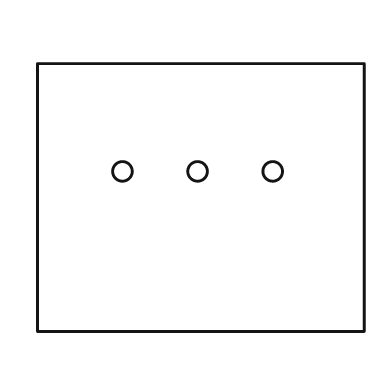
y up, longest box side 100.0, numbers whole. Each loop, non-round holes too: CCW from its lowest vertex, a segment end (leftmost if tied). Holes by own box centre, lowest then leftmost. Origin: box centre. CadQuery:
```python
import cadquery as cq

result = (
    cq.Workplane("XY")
    .moveTo(-50.0, -41.0)
    .lineTo(50.0, -41.0)
    .lineTo(50.0, 41.0)
    .lineTo(-50.0, 41.0)
    .close()
    .moveTo(-24.0, 8.0)
    .circle(3.0)
    .moveTo(-1.0, 8.0)
    .circle(3.0)
    .moveTo(22.0, 8.0)
    .circle(3.0)
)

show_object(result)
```